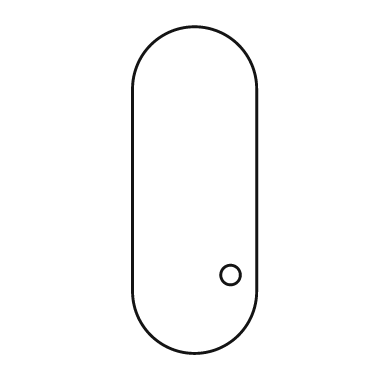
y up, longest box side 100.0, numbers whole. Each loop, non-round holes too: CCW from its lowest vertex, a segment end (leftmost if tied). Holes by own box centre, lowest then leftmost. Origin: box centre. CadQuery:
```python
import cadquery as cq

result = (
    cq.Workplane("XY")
    .moveTo(-19.0, -31.0)
    .threePointArc((0.0, -50.0), (19.0, -31.0))
    .lineTo(19.0, 31.0)
    .threePointArc((0.0, 50.0), (-19.0, 31.0))
    .close()
    .moveTo(11.0, -26.0)
    .circle(3.0)
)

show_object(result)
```